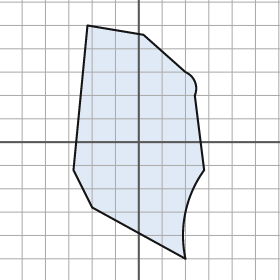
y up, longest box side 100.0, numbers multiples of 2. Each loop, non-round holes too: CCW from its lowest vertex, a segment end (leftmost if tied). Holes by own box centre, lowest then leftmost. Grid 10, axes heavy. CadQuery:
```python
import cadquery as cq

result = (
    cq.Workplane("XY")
    .moveTo(20.0, -50.0)
    .threePointArc((20.0, -30.0), (28.0, -12.0))
    .lineTo(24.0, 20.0)
    .threePointArc((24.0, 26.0), (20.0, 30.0))
    .lineTo(2.0, 46.0)
    .lineTo(-22.0, 50.0)
    .lineTo(-28.0, -12.0)
    .lineTo(-20.0, -28.0)
    .close()
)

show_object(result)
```